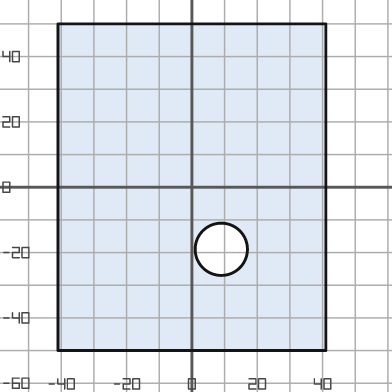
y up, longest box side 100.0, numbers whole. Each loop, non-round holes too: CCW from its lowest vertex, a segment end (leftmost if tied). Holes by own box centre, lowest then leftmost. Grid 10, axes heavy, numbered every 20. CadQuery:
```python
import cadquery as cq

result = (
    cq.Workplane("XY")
    .moveTo(-41.0, -50.0)
    .lineTo(41.0, -50.0)
    .lineTo(41.0, 50.0)
    .lineTo(-41.0, 50.0)
    .close()
    .moveTo(9.0, -19.0)
    .circle(8.0)
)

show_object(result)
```